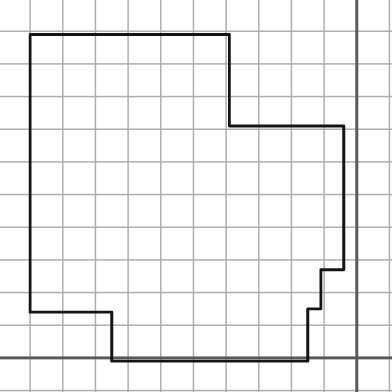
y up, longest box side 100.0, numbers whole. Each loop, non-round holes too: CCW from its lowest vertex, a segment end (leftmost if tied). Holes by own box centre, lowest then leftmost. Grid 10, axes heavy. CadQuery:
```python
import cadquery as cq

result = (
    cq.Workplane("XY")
    .moveTo(-75.0, -1.0)
    .lineTo(-15.0, -1.0)
    .lineTo(-15.0, 15.0)
    .lineTo(-11.0, 15.0)
    .lineTo(-11.0, 27.0)
    .lineTo(-4.0, 27.0)
    .lineTo(-4.0, 71.0)
    .lineTo(-39.0, 71.0)
    .lineTo(-39.0, 99.0)
    .lineTo(-100.0, 99.0)
    .lineTo(-100.0, 14.0)
    .lineTo(-75.0, 14.0)
    .close()
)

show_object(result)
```